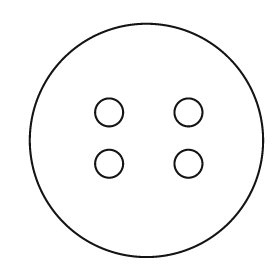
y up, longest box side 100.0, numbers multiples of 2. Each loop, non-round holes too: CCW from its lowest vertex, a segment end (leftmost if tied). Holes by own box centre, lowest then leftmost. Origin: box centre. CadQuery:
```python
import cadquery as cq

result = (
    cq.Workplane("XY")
    .moveTo(0.0, 0.0)
    .circle(50.0)
    .moveTo(-16.0, -10.0)
    .circle(6.0)
    .moveTo(18.0, -10.0)
    .circle(6.0)
    .moveTo(-16.0, 12.0)
    .circle(6.0)
    .moveTo(18.0, 12.0)
    .circle(6.0)
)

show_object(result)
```